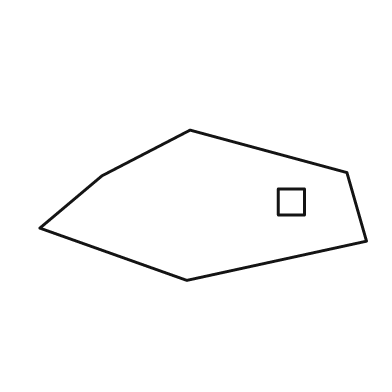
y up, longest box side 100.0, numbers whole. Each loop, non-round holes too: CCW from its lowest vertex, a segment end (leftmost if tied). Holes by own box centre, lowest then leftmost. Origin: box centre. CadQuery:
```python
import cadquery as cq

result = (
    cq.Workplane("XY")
    .moveTo(-5.0, -23.0)
    .lineTo(50.0, -11.0)
    .lineTo(44.0, 10.0)
    .lineTo(-4.0, 23.0)
    .lineTo(-31.0, 9.0)
    .lineTo(-50.0, -7.0)
    .close()
    .moveTo(23.0, -3.0)
    .lineTo(31.0, -3.0)
    .lineTo(31.0, 5.0)
    .lineTo(23.0, 5.0)
    .close()
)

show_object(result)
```